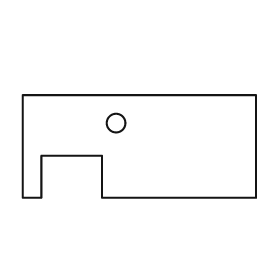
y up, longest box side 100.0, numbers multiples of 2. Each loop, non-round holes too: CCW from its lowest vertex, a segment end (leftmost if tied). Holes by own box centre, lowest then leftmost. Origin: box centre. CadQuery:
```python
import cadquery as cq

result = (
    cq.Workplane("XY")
    .moveTo(-50.0, -22.0)
    .lineTo(-42.0, -22.0)
    .lineTo(-42.0, -4.0)
    .lineTo(-16.0, -4.0)
    .lineTo(-16.0, -22.0)
    .lineTo(50.0, -22.0)
    .lineTo(50.0, 22.0)
    .lineTo(-50.0, 22.0)
    .close()
    .moveTo(-10.0, 10.0)
    .circle(4.0)
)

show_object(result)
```